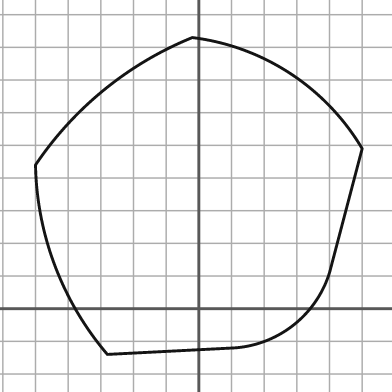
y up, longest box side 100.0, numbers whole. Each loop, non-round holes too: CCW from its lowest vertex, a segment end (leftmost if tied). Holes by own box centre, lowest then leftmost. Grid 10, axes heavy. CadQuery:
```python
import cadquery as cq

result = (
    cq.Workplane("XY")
    .moveTo(-28.0, -14.0)
    .lineTo(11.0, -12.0)
    .threePointArc((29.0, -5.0), (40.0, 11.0))
    .lineTo(50.0, 49.0)
    .threePointArc((28.0, 72.0), (-2.0, 83.0))
    .threePointArc((-29.0, 67.0), (-50.0, 44.0))
    .threePointArc((-44.0, 13.0), (-28.0, -14.0))
    .close()
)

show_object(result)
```